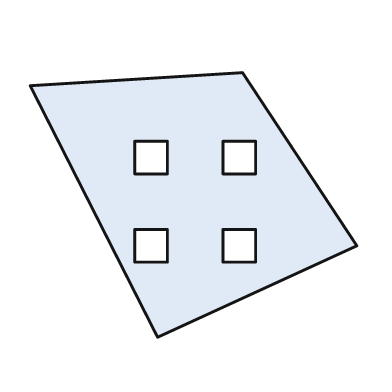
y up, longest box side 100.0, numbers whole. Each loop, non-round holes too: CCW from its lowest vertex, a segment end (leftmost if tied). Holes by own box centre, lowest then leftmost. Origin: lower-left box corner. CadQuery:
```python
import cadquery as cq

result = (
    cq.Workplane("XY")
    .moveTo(39.0, 0.0)
    .lineTo(100.0, 28.0)
    .lineTo(65.0, 81.0)
    .lineTo(0.0, 77.0)
    .close()
    .moveTo(32.0, 23.0)
    .lineTo(42.0, 23.0)
    .lineTo(42.0, 33.0)
    .lineTo(32.0, 33.0)
    .close()
    .moveTo(59.0, 23.0)
    .lineTo(69.0, 23.0)
    .lineTo(69.0, 33.0)
    .lineTo(59.0, 33.0)
    .close()
    .moveTo(32.0, 50.0)
    .lineTo(42.0, 50.0)
    .lineTo(42.0, 60.0)
    .lineTo(32.0, 60.0)
    .close()
    .moveTo(59.0, 50.0)
    .lineTo(69.0, 50.0)
    .lineTo(69.0, 60.0)
    .lineTo(59.0, 60.0)
    .close()
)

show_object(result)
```